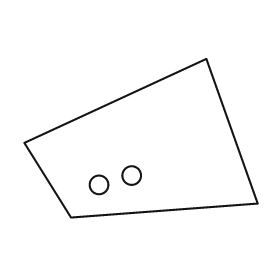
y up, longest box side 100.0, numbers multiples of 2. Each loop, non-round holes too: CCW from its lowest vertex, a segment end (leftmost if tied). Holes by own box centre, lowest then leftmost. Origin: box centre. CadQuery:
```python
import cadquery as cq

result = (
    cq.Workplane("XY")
    .moveTo(-30.0, -34.0)
    .lineTo(50.0, -28.0)
    .lineTo(28.0, 34.0)
    .lineTo(-50.0, -2.0)
    .close()
    .moveTo(-18.0, -20.0)
    .circle(4.0)
    .moveTo(-4.0, -16.0)
    .circle(4.0)
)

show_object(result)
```